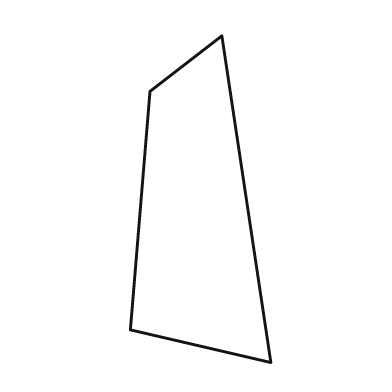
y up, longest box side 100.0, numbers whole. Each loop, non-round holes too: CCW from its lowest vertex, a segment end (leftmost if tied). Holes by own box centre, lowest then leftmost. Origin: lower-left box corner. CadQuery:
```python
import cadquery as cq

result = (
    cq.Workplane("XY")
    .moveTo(43.0, 0.0)
    .lineTo(28.0, 100.0)
    .lineTo(6.0, 83.0)
    .lineTo(0.0, 10.0)
    .close()
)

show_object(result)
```